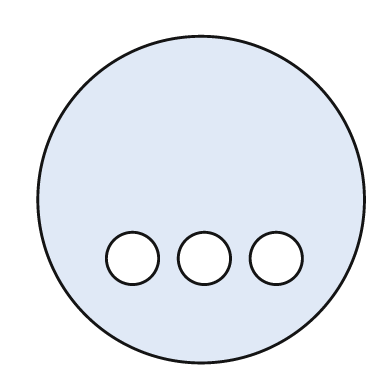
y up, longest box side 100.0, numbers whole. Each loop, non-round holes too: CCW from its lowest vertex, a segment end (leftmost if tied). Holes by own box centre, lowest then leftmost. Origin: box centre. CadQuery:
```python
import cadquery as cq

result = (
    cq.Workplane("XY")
    .moveTo(0.0, 0.0)
    .circle(50.0)
    .moveTo(-21.0, -18.0)
    .circle(8.0)
    .moveTo(1.0, -18.0)
    .circle(8.0)
    .moveTo(23.0, -18.0)
    .circle(8.0)
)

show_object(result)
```